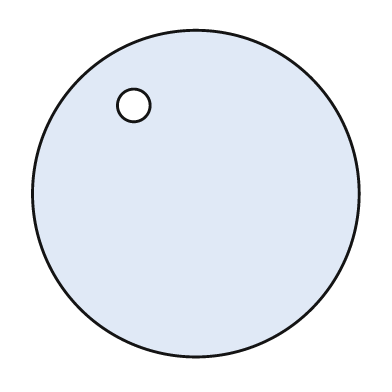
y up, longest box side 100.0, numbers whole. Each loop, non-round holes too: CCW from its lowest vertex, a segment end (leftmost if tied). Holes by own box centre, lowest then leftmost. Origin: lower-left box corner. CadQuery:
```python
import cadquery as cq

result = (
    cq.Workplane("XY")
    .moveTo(50.0, 50.0)
    .circle(50.0)
    .moveTo(31.0, 77.0)
    .circle(5.0)
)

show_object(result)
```